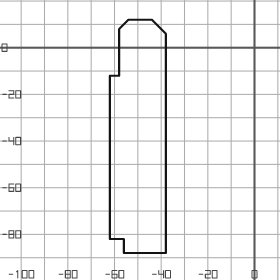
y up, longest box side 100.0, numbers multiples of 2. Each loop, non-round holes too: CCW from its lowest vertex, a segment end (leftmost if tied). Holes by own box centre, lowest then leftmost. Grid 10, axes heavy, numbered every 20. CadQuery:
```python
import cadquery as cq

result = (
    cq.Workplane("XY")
    .moveTo(-56.0, -88.0)
    .lineTo(-38.0, -88.0)
    .lineTo(-38.0, 6.0)
    .lineTo(-44.0, 12.0)
    .lineTo(-54.0, 12.0)
    .lineTo(-58.0, 8.0)
    .lineTo(-58.0, -12.0)
    .lineTo(-62.0, -12.0)
    .lineTo(-62.0, -82.0)
    .lineTo(-56.0, -82.0)
    .close()
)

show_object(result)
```